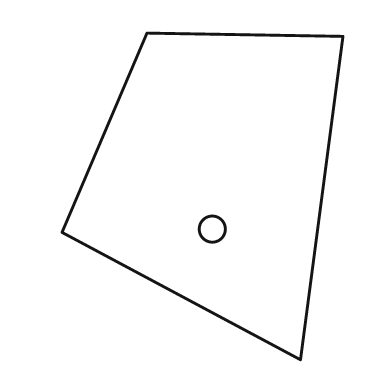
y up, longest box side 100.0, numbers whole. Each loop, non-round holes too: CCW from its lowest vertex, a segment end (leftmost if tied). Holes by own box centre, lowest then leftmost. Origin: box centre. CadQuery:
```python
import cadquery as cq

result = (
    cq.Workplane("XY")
    .moveTo(30.0, -50.0)
    .lineTo(43.0, 49.0)
    .lineTo(-17.0, 50.0)
    .lineTo(-43.0, -11.0)
    .close()
    .moveTo(3.0, -10.0)
    .circle(4.0)
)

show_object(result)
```